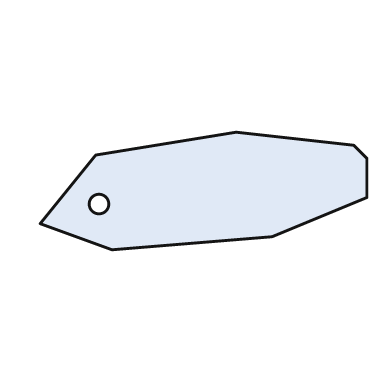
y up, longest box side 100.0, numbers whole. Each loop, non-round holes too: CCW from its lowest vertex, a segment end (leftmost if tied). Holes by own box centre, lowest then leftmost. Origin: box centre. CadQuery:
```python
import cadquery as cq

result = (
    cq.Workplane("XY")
    .moveTo(-28.0, -18.0)
    .lineTo(21.0, -14.0)
    .lineTo(50.0, -2.0)
    .lineTo(50.0, 10.0)
    .lineTo(46.0, 14.0)
    .lineTo(10.0, 18.0)
    .lineTo(-33.0, 11.0)
    .lineTo(-50.0, -10.0)
    .close()
    .moveTo(-32.0, -4.0)
    .circle(3.0)
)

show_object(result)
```